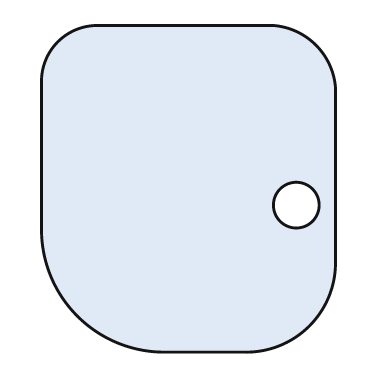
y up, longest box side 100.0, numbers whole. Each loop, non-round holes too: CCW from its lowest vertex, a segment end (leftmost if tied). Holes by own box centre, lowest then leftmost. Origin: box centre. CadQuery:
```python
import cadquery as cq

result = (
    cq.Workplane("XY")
    .moveTo(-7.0, -50.0)
    .lineTo(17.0, -50.0)
    .threePointArc((37.0, -42.0), (45.0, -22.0))
    .lineTo(45.0, 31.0)
    .threePointArc((39.0, 44.0), (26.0, 50.0))
    .lineTo(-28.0, 50.0)
    .threePointArc((-40.0, 45.0), (-45.0, 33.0))
    .lineTo(-45.0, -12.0)
    .threePointArc((-34.0, -39.0), (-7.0, -50.0))
    .close()
    .moveTo(33.0, -5.0)
    .circle(7.0)
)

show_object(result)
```